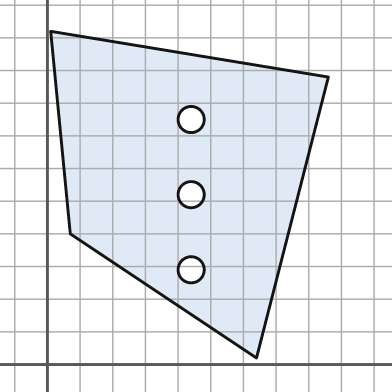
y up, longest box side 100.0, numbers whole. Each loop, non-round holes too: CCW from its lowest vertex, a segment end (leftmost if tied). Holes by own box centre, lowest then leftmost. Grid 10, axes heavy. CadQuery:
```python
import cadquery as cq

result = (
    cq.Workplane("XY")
    .moveTo(64.0, 2.0)
    .lineTo(86.0, 88.0)
    .lineTo(1.0, 102.0)
    .lineTo(7.0, 40.0)
    .close()
    .moveTo(44.0, 29.0)
    .circle(4.0)
    .moveTo(44.0, 52.0)
    .circle(4.0)
    .moveTo(44.0, 75.0)
    .circle(4.0)
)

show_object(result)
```